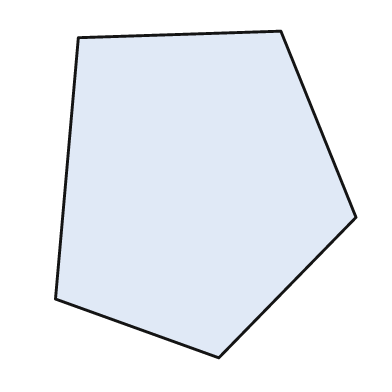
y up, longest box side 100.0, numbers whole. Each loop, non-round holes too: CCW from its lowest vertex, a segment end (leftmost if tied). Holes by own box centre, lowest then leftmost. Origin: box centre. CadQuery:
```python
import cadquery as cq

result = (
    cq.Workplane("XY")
    .moveTo(4.0, -50.0)
    .lineTo(46.0, -7.0)
    .lineTo(23.0, 50.0)
    .lineTo(-39.0, 48.0)
    .lineTo(-46.0, -32.0)
    .close()
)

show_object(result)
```